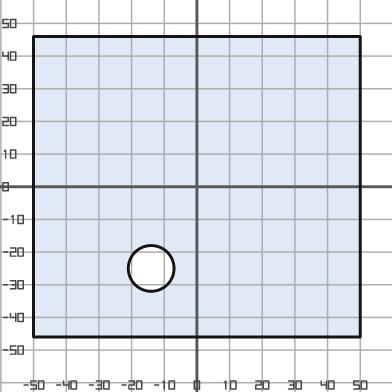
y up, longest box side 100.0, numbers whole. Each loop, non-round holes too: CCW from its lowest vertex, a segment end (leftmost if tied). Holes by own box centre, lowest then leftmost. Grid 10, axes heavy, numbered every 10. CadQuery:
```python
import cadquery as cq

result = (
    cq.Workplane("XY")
    .moveTo(-50.0, -46.0)
    .lineTo(50.0, -46.0)
    .lineTo(50.0, 46.0)
    .lineTo(-50.0, 46.0)
    .close()
    .moveTo(-14.0, -25.0)
    .circle(7.0)
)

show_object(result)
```